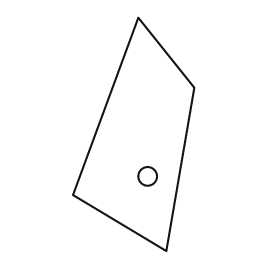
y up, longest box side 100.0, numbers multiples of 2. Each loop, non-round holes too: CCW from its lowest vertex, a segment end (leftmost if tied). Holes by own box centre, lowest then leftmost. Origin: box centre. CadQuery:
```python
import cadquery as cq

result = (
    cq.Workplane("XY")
    .moveTo(14.0, -50.0)
    .lineTo(26.0, 20.0)
    .lineTo(2.0, 50.0)
    .lineTo(-26.0, -26.0)
    .close()
    .moveTo(6.0, -18.0)
    .circle(4.0)
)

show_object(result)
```